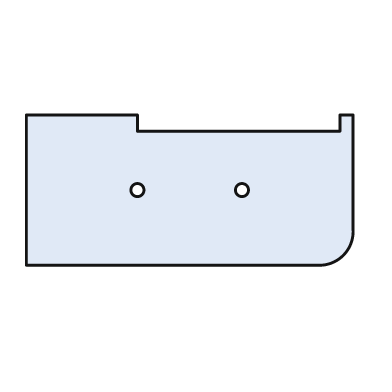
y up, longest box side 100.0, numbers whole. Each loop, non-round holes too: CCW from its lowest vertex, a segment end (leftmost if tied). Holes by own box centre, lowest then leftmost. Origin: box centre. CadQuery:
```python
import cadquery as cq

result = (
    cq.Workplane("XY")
    .moveTo(-50.0, -23.0)
    .lineTo(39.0, -23.0)
    .threePointArc((47.0, -20.0), (50.0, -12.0))
    .lineTo(50.0, 23.0)
    .lineTo(46.0, 23.0)
    .lineTo(46.0, 18.0)
    .lineTo(-16.0, 18.0)
    .lineTo(-16.0, 23.0)
    .lineTo(-50.0, 23.0)
    .close()
    .moveTo(-16.0, 0.0)
    .circle(2.0)
    .moveTo(16.0, 0.0)
    .circle(2.0)
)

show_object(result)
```